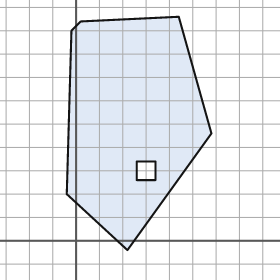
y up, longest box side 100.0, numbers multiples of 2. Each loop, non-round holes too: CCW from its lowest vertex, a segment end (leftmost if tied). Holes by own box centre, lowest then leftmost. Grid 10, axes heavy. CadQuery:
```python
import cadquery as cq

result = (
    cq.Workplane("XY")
    .moveTo(22.0, -4.0)
    .lineTo(58.0, 46.0)
    .lineTo(44.0, 96.0)
    .lineTo(2.0, 94.0)
    .lineTo(-2.0, 90.0)
    .lineTo(-4.0, 20.0)
    .close()
    .moveTo(26.0, 26.0)
    .lineTo(34.0, 26.0)
    .lineTo(34.0, 34.0)
    .lineTo(26.0, 34.0)
    .close()
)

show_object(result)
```